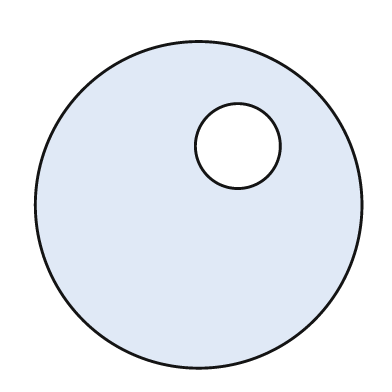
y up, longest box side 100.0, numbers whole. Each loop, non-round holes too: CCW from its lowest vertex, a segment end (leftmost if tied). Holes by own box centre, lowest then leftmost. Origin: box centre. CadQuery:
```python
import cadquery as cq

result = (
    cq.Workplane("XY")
    .moveTo(0.0, 0.0)
    .circle(50.0)
    .moveTo(12.0, 18.0)
    .circle(13.0)
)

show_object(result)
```